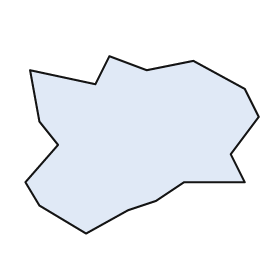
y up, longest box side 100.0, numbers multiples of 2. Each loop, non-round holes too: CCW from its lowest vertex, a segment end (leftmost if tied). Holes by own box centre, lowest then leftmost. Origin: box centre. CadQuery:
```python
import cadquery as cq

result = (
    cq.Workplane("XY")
    .moveTo(-24.0, -38.0)
    .lineTo(-6.0, -28.0)
    .lineTo(6.0, -24.0)
    .lineTo(18.0, -16.0)
    .lineTo(44.0, -16.0)
    .lineTo(38.0, -4.0)
    .lineTo(50.0, 12.0)
    .lineTo(44.0, 24.0)
    .lineTo(22.0, 36.0)
    .lineTo(2.0, 32.0)
    .lineTo(-14.0, 38.0)
    .lineTo(-20.0, 26.0)
    .lineTo(-48.0, 32.0)
    .lineTo(-44.0, 10.0)
    .lineTo(-36.0, 0.0)
    .lineTo(-50.0, -16.0)
    .lineTo(-44.0, -26.0)
    .close()
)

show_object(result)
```